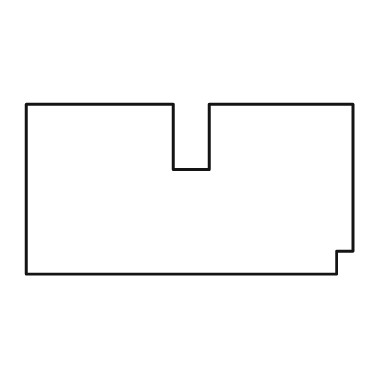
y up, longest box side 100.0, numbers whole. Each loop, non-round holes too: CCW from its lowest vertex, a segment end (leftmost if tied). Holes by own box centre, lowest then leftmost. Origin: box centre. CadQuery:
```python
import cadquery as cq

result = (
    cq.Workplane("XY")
    .moveTo(-50.0, -26.0)
    .lineTo(45.0, -26.0)
    .lineTo(45.0, -19.0)
    .lineTo(50.0, -19.0)
    .lineTo(50.0, 26.0)
    .lineTo(6.0, 26.0)
    .lineTo(6.0, 6.0)
    .lineTo(-5.0, 6.0)
    .lineTo(-5.0, 26.0)
    .lineTo(-50.0, 26.0)
    .close()
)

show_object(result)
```